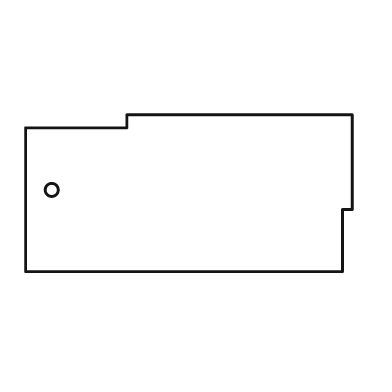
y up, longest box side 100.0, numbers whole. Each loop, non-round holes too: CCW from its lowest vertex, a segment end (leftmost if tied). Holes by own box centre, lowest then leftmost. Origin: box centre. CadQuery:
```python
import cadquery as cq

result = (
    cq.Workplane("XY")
    .moveTo(-50.0, -24.0)
    .lineTo(47.0, -24.0)
    .lineTo(47.0, -5.0)
    .lineTo(50.0, -5.0)
    .lineTo(50.0, 24.0)
    .lineTo(-19.0, 24.0)
    .lineTo(-19.0, 20.0)
    .lineTo(-50.0, 20.0)
    .close()
    .moveTo(-42.0, 1.0)
    .circle(2.0)
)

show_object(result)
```